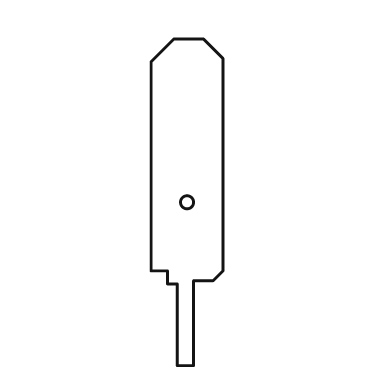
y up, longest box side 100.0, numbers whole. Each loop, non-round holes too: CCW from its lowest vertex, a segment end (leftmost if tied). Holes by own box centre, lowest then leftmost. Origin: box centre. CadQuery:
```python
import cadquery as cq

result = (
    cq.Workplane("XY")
    .moveTo(-3.0, -50.0)
    .lineTo(2.0, -50.0)
    .lineTo(2.0, -24.0)
    .lineTo(8.0, -24.0)
    .lineTo(11.0, -21.0)
    .lineTo(11.0, 44.0)
    .lineTo(5.0, 50.0)
    .lineTo(-4.0, 50.0)
    .lineTo(-11.0, 43.0)
    .lineTo(-11.0, -21.0)
    .lineTo(-6.0, -21.0)
    .lineTo(-6.0, -25.0)
    .lineTo(-3.0, -25.0)
    .close()
    .moveTo(0.0, 0.0)
    .circle(2.0)
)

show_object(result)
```